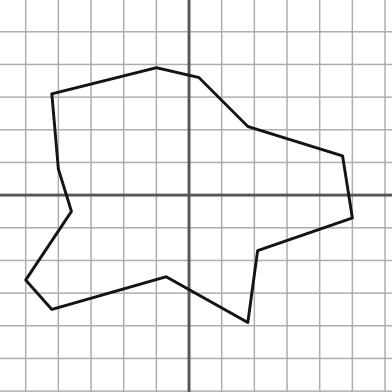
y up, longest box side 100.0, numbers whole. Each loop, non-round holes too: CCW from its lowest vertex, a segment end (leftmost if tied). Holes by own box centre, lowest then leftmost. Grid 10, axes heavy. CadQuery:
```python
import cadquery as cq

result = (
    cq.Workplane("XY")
    .moveTo(18.0, -39.0)
    .lineTo(21.0, -17.0)
    .lineTo(50.0, -7.0)
    .lineTo(47.0, 12.0)
    .lineTo(18.0, 21.0)
    .lineTo(3.0, 36.0)
    .lineTo(-10.0, 39.0)
    .lineTo(-42.0, 31.0)
    .lineTo(-40.0, 8.0)
    .lineTo(-36.0, -5.0)
    .lineTo(-50.0, -26.0)
    .lineTo(-42.0, -35.0)
    .lineTo(-7.0, -25.0)
    .close()
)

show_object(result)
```